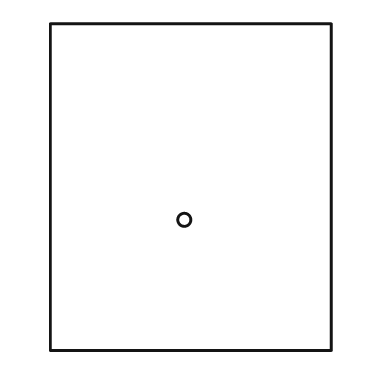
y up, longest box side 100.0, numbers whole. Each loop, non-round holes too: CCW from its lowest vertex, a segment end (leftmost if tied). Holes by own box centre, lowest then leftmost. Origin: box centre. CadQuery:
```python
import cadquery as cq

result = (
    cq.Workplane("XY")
    .moveTo(-43.0, -50.0)
    .lineTo(43.0, -50.0)
    .lineTo(43.0, 50.0)
    .lineTo(-43.0, 50.0)
    .close()
    .moveTo(-2.0, -10.0)
    .circle(2.0)
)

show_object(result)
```